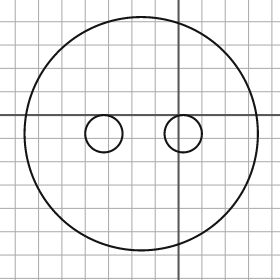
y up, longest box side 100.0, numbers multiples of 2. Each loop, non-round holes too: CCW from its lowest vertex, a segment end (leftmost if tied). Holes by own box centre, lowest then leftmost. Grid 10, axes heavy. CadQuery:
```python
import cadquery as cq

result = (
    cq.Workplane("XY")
    .moveTo(-16.0, -8.0)
    .circle(50.0)
    .moveTo(-32.0, -8.0)
    .circle(8.0)
    .moveTo(2.0, -8.0)
    .circle(8.0)
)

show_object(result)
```